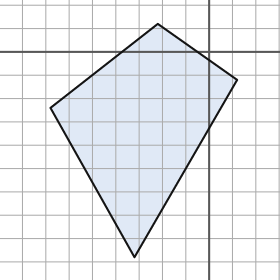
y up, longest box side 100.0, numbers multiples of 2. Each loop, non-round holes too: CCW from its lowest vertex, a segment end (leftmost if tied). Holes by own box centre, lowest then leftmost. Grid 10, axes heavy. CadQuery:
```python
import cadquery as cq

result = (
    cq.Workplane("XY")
    .moveTo(-32.0, -88.0)
    .lineTo(12.0, -12.0)
    .lineTo(-22.0, 12.0)
    .lineTo(-68.0, -24.0)
    .close()
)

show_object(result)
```